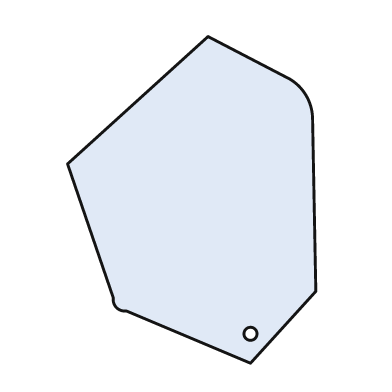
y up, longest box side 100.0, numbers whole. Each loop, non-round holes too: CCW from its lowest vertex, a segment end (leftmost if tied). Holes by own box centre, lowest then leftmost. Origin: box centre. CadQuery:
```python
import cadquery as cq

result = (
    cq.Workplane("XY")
    .moveTo(18.0, -50.0)
    .lineTo(38.0, -28.0)
    .lineTo(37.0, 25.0)
    .threePointArc((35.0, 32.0), (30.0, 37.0))
    .lineTo(5.0, 50.0)
    .lineTo(-38.0, 11.0)
    .lineTo(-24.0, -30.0)
    .threePointArc((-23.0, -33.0), (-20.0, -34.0))
    .close()
    .moveTo(18.0, -41.0)
    .circle(2.0)
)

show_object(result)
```